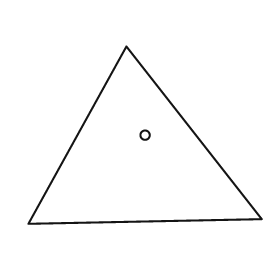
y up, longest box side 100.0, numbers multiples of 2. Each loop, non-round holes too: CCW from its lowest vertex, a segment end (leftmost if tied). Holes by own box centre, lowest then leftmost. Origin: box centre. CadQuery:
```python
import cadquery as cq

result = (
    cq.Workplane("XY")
    .moveTo(-50.0, -38.0)
    .lineTo(50.0, -36.0)
    .lineTo(-8.0, 38.0)
    .close()
    .moveTo(0.0, 0.0)
    .circle(2.0)
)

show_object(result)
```